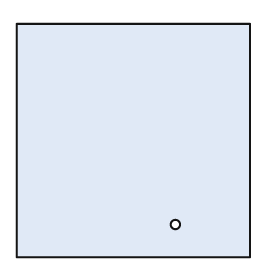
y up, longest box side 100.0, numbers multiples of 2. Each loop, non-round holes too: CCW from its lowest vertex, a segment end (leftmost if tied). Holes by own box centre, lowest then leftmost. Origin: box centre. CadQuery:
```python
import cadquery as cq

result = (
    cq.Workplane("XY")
    .moveTo(-50.0, -50.0)
    .lineTo(50.0, -50.0)
    .lineTo(50.0, 50.0)
    .lineTo(-50.0, 50.0)
    .close()
    .moveTo(18.0, -36.0)
    .circle(2.0)
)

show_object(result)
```